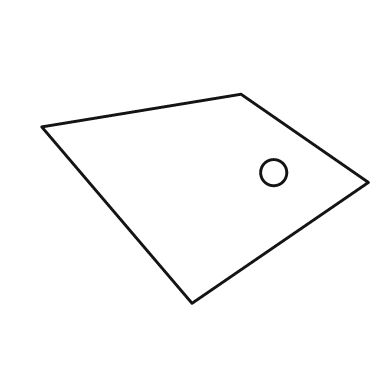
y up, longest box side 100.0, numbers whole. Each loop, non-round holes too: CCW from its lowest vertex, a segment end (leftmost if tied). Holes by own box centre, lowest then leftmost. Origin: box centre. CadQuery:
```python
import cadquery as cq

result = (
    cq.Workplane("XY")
    .moveTo(-4.0, -32.0)
    .lineTo(50.0, 5.0)
    .lineTo(11.0, 32.0)
    .lineTo(-50.0, 22.0)
    .close()
    .moveTo(21.0, 8.0)
    .circle(4.0)
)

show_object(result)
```